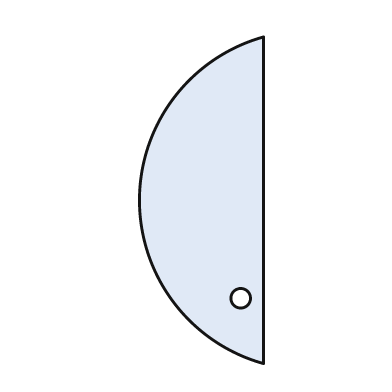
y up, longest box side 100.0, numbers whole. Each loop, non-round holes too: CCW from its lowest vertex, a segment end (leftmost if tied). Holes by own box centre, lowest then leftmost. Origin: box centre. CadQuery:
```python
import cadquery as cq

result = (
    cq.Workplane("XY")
    .moveTo(19.0, -50.0)
    .lineTo(19.0, 50.0)
    .threePointArc((-19.0, 0.0), (19.0, -50.0))
    .close()
    .moveTo(12.0, -30.0)
    .circle(3.0)
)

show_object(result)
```